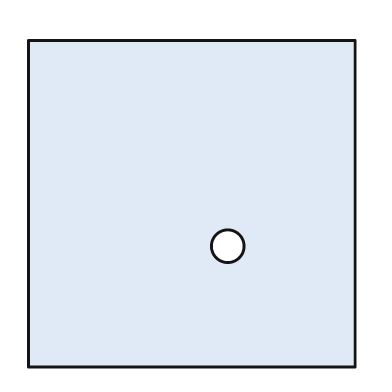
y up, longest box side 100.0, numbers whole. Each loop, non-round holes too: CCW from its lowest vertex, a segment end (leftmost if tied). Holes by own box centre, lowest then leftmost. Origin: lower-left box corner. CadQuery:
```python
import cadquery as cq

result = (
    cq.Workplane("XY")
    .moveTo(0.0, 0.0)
    .lineTo(100.0, 0.0)
    .lineTo(100.0, 100.0)
    .lineTo(0.0, 100.0)
    .close()
    .moveTo(61.0, 37.0)
    .circle(5.0)
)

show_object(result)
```